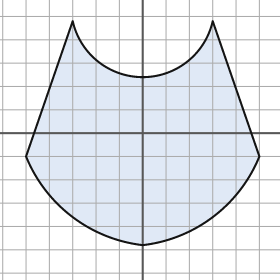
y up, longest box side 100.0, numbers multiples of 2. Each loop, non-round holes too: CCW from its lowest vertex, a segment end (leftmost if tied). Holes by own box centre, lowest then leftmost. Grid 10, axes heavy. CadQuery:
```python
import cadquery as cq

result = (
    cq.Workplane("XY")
    .moveTo(0.0, -48.0)
    .threePointArc((30.0, -36.0), (50.0, -10.0))
    .lineTo(30.0, 48.0)
    .threePointArc((0.0, 24.0), (-30.0, 48.0))
    .lineTo(-50.0, -10.0)
    .threePointArc((-30.0, -36.0), (0.0, -48.0))
    .close()
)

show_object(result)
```